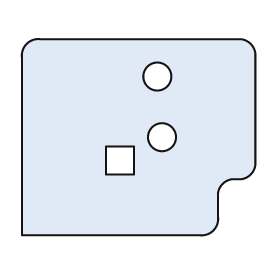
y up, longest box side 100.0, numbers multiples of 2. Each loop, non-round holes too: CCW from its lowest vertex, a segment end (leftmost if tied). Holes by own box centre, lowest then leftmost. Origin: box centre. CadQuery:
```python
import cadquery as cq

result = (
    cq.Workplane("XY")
    .moveTo(-50.0, -42.0)
    .lineTo(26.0, -42.0)
    .threePointArc((32.0, -40.0), (34.0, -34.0))
    .lineTo(34.0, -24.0)
    .threePointArc((36.0, -20.0), (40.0, -18.0))
    .lineTo(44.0, -18.0)
    .threePointArc((48.0, -16.0), (50.0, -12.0))
    .lineTo(50.0, 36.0)
    .threePointArc((48.0, 40.0), (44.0, 42.0))
    .lineTo(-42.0, 42.0)
    .threePointArc((-48.0, 40.0), (-50.0, 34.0))
    .close()
    .moveTo(-14.0, -16.0)
    .lineTo(-2.0, -16.0)
    .lineTo(-2.0, -4.0)
    .lineTo(-14.0, -4.0)
    .close()
    .moveTo(10.0, 0.0)
    .circle(6.0)
    .moveTo(8.0, 26.0)
    .circle(6.0)
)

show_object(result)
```